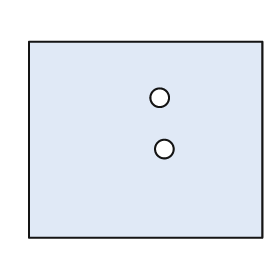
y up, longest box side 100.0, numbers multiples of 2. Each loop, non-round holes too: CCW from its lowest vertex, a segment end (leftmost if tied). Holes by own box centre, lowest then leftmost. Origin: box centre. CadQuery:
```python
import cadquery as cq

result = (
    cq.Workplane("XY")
    .moveTo(-50.0, -42.0)
    .lineTo(50.0, -42.0)
    .lineTo(50.0, 42.0)
    .lineTo(-50.0, 42.0)
    .close()
    .moveTo(8.0, -4.0)
    .circle(4.0)
    .moveTo(6.0, 18.0)
    .circle(4.0)
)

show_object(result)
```